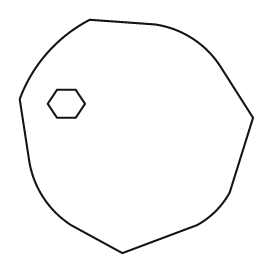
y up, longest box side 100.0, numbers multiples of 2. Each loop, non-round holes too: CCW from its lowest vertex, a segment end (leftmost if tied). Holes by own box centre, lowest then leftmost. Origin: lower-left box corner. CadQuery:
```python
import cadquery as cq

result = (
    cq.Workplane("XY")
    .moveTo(44.0, 0.0)
    .lineTo(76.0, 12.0)
    .threePointArc((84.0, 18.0), (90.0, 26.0))
    .lineTo(100.0, 58.0)
    .lineTo(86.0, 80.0)
    .threePointArc((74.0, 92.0), (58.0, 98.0))
    .lineTo(30.0, 100.0)
    .threePointArc((12.0, 86.0), (0.0, 66.0))
    .lineTo(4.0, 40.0)
    .threePointArc((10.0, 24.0), (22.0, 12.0))
    .close()
    .moveTo(16.0, 58.0)
    .lineTo(24.0, 58.0)
    .lineTo(28.0, 64.0)
    .lineTo(24.0, 70.0)
    .lineTo(16.0, 70.0)
    .lineTo(12.0, 64.0)
    .close()
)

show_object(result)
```